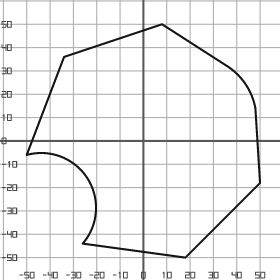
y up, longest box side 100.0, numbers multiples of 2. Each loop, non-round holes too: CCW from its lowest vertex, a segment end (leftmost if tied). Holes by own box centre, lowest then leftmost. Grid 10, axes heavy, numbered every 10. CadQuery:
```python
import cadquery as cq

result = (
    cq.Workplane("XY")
    .moveTo(18.0, -50.0)
    .lineTo(50.0, -18.0)
    .lineTo(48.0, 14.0)
    .threePointArc((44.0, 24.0), (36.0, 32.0))
    .lineTo(8.0, 50.0)
    .lineTo(-34.0, 36.0)
    .lineTo(-50.0, -6.0)
    .threePointArc((-24.0, -16.0), (-26.0, -44.0))
    .close()
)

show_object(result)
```